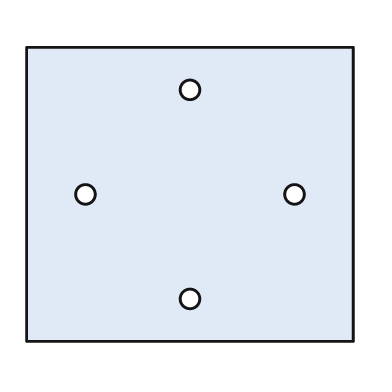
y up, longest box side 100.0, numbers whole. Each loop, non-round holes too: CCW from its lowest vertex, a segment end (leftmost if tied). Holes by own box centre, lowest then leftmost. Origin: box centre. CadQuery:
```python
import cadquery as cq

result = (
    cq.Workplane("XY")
    .moveTo(-50.0, -45.0)
    .lineTo(50.0, -45.0)
    .lineTo(50.0, 45.0)
    .lineTo(-50.0, 45.0)
    .close()
    .moveTo(0.0, -32.0)
    .circle(3.0)
    .moveTo(-32.0, 0.0)
    .circle(3.0)
    .moveTo(32.0, 0.0)
    .circle(3.0)
    .moveTo(0.0, 32.0)
    .circle(3.0)
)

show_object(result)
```